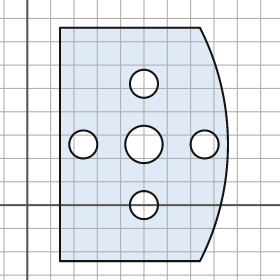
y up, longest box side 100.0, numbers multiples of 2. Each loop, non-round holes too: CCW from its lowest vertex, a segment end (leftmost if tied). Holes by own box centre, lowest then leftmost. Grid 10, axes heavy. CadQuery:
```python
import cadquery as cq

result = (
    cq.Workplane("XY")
    .moveTo(14.0, -24.0)
    .lineTo(74.0, -24.0)
    .threePointArc((86.0, 26.0), (74.0, 76.0))
    .lineTo(14.0, 76.0)
    .close()
    .moveTo(50.0, 0.0)
    .circle(6.0)
    .moveTo(24.0, 26.0)
    .circle(6.0)
    .moveTo(50.0, 26.0)
    .circle(8.0)
    .moveTo(76.0, 26.0)
    .circle(6.0)
    .moveTo(50.0, 52.0)
    .circle(6.0)
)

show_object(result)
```